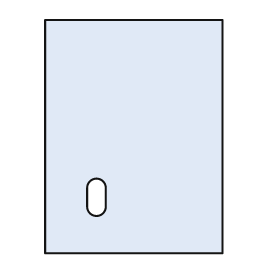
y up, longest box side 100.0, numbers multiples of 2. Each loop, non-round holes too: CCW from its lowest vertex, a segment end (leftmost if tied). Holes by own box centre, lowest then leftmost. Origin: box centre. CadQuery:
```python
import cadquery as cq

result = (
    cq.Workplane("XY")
    .moveTo(-38.0, -50.0)
    .lineTo(38.0, -50.0)
    .lineTo(38.0, 50.0)
    .lineTo(-38.0, 50.0)
    .close()
    .moveTo(-20.0, -30.0)
    .threePointArc((-16.0, -34.0), (-12.0, -30.0))
    .lineTo(-12.0, -22.0)
    .threePointArc((-16.0, -18.0), (-20.0, -22.0))
    .close()
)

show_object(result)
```